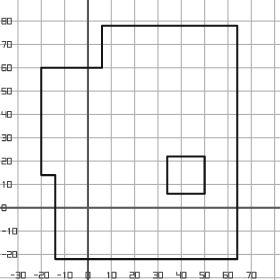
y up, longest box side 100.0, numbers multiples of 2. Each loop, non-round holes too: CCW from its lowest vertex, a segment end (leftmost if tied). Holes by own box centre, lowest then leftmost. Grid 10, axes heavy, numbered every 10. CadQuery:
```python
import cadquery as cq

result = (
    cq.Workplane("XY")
    .moveTo(-14.0, -22.0)
    .lineTo(64.0, -22.0)
    .lineTo(64.0, 78.0)
    .lineTo(6.0, 78.0)
    .lineTo(6.0, 60.0)
    .lineTo(-20.0, 60.0)
    .lineTo(-20.0, 14.0)
    .lineTo(-14.0, 14.0)
    .close()
    .moveTo(34.0, 6.0)
    .lineTo(50.0, 6.0)
    .lineTo(50.0, 22.0)
    .lineTo(34.0, 22.0)
    .close()
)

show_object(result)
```